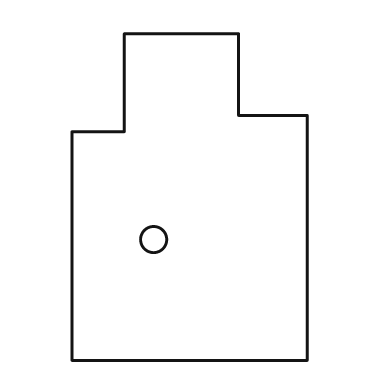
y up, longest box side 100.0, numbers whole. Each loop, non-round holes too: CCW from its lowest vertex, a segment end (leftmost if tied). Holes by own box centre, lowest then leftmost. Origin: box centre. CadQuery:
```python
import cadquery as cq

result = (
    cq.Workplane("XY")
    .moveTo(-36.0, -50.0)
    .lineTo(36.0, -50.0)
    .lineTo(36.0, 25.0)
    .lineTo(15.0, 25.0)
    .lineTo(15.0, 50.0)
    .lineTo(-20.0, 50.0)
    .lineTo(-20.0, 20.0)
    .lineTo(-36.0, 20.0)
    .close()
    .moveTo(-11.0, -13.0)
    .circle(4.0)
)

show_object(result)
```